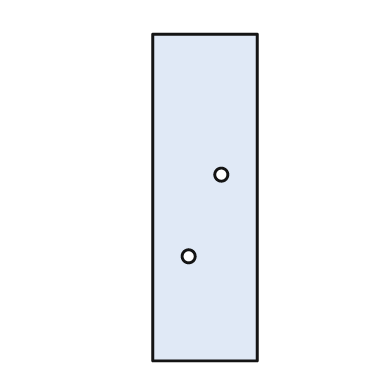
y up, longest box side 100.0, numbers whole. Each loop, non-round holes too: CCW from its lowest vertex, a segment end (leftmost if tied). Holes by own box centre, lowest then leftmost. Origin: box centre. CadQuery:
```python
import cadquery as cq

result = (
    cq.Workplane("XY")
    .moveTo(-16.0, -50.0)
    .lineTo(16.0, -50.0)
    .lineTo(16.0, 50.0)
    .lineTo(-16.0, 50.0)
    .close()
    .moveTo(-5.0, -18.0)
    .circle(2.0)
    .moveTo(5.0, 7.0)
    .circle(2.0)
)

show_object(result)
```